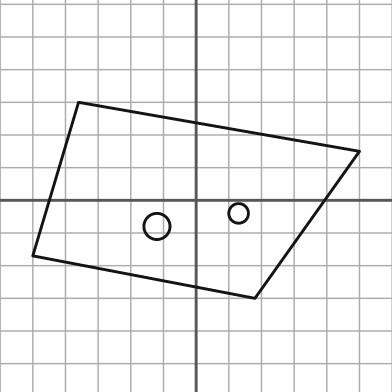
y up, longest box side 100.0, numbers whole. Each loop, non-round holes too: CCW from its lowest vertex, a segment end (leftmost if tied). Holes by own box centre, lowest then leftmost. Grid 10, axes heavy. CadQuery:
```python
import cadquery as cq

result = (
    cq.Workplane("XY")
    .moveTo(18.0, -30.0)
    .lineTo(50.0, 15.0)
    .lineTo(-36.0, 30.0)
    .lineTo(-50.0, -17.0)
    .close()
    .moveTo(-12.0, -8.0)
    .circle(4.0)
    .moveTo(13.0, -4.0)
    .circle(3.0)
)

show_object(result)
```